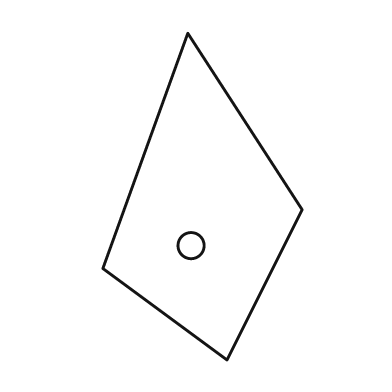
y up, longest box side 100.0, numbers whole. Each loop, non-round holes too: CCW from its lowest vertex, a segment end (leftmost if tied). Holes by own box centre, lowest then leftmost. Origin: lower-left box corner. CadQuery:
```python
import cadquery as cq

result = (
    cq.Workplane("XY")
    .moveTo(38.0, 0.0)
    .lineTo(61.0, 46.0)
    .lineTo(26.0, 100.0)
    .lineTo(0.0, 28.0)
    .close()
    .moveTo(27.0, 35.0)
    .circle(4.0)
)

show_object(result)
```